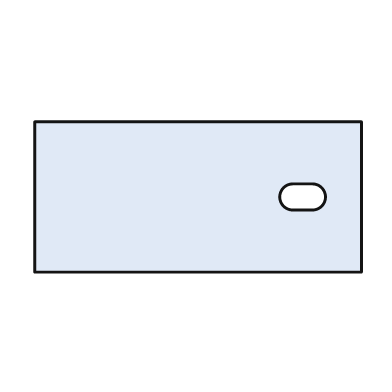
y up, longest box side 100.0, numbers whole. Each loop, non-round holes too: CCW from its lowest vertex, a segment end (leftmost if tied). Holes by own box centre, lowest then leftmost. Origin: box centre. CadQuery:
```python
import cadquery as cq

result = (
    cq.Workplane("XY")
    .moveTo(-50.0, -23.0)
    .lineTo(50.0, -23.0)
    .lineTo(50.0, 23.0)
    .lineTo(-50.0, 23.0)
    .close()
    .moveTo(29.0, -4.0)
    .lineTo(35.0, -4.0)
    .threePointArc((39.0, 0.0), (35.0, 4.0))
    .lineTo(29.0, 4.0)
    .threePointArc((25.0, 0.0), (29.0, -4.0))
    .close()
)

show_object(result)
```